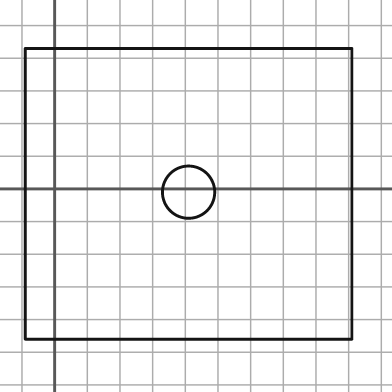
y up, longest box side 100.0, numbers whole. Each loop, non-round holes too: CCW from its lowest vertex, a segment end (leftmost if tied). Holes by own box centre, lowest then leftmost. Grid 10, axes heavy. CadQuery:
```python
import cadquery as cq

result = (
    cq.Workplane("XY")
    .moveTo(-9.0, -46.0)
    .lineTo(91.0, -46.0)
    .lineTo(91.0, 43.0)
    .lineTo(-9.0, 43.0)
    .close()
    .moveTo(41.0, -1.0)
    .circle(8.0)
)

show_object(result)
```